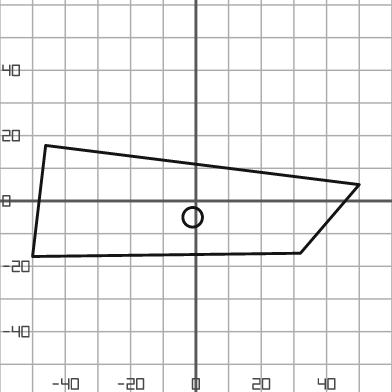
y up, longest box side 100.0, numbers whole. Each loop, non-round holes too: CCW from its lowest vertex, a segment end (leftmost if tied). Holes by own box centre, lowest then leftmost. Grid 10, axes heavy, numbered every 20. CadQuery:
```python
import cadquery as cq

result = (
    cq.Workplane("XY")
    .moveTo(-50.0, -17.0)
    .lineTo(32.0, -16.0)
    .lineTo(50.0, 5.0)
    .lineTo(-46.0, 17.0)
    .close()
    .moveTo(-1.0, -5.0)
    .circle(3.0)
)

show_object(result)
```